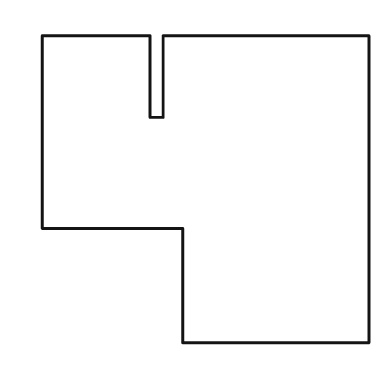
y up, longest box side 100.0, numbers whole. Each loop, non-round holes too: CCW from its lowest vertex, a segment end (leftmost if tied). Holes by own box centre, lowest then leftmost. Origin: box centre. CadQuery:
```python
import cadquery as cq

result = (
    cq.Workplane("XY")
    .moveTo(-7.0, -47.0)
    .lineTo(50.0, -47.0)
    .lineTo(50.0, 47.0)
    .lineTo(-13.0, 47.0)
    .lineTo(-13.0, 22.0)
    .lineTo(-17.0, 22.0)
    .lineTo(-17.0, 47.0)
    .lineTo(-50.0, 47.0)
    .lineTo(-50.0, -12.0)
    .lineTo(-7.0, -12.0)
    .close()
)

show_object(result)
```